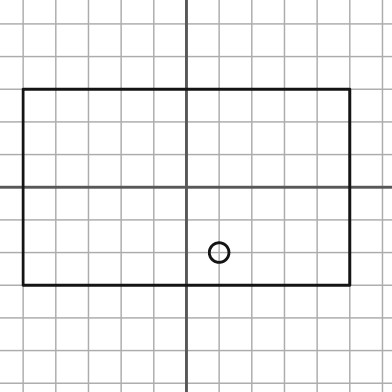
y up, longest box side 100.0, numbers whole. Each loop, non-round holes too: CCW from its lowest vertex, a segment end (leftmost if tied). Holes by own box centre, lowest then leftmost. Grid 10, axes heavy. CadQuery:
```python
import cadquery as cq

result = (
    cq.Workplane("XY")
    .moveTo(-50.0, -30.0)
    .lineTo(50.0, -30.0)
    .lineTo(50.0, 30.0)
    .lineTo(-50.0, 30.0)
    .close()
    .moveTo(10.0, -20.0)
    .circle(3.0)
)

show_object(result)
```